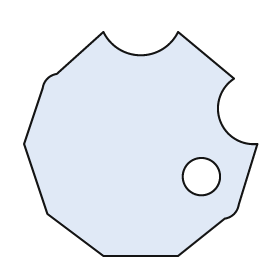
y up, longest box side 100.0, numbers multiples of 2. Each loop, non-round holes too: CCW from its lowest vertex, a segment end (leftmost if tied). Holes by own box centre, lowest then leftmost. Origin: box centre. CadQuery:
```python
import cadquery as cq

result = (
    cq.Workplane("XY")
    .moveTo(-16.0, -48.0)
    .lineTo(16.0, -48.0)
    .lineTo(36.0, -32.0)
    .threePointArc((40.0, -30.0), (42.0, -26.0))
    .lineTo(50.0, 0.0)
    .threePointArc((34.0, 10.0), (40.0, 28.0))
    .lineTo(16.0, 48.0)
    .threePointArc((0.0, 38.0), (-16.0, 48.0))
    .lineTo(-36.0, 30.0)
    .threePointArc((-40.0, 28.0), (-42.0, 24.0))
    .lineTo(-50.0, 0.0)
    .lineTo(-40.0, -30.0)
    .close()
    .moveTo(26.0, -14.0)
    .circle(8.0)
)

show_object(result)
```